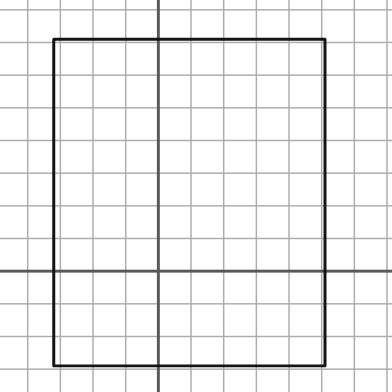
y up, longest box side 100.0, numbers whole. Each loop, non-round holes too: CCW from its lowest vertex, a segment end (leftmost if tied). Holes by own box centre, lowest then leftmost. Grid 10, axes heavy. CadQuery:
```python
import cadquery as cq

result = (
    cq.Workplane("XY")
    .moveTo(-32.0, -29.0)
    .lineTo(51.0, -29.0)
    .lineTo(51.0, 71.0)
    .lineTo(-32.0, 71.0)
    .close()
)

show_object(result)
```